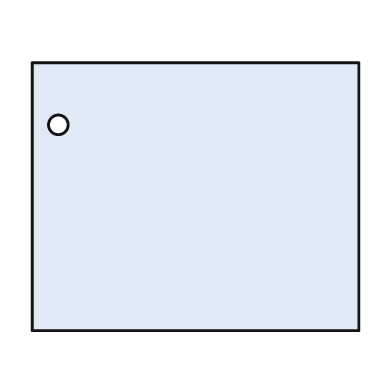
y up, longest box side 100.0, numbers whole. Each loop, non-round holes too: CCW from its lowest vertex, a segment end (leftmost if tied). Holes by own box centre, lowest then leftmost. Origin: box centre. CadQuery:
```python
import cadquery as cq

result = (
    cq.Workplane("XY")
    .moveTo(-50.0, -41.0)
    .lineTo(50.0, -41.0)
    .lineTo(50.0, 41.0)
    .lineTo(-50.0, 41.0)
    .close()
    .moveTo(-42.0, 22.0)
    .circle(3.0)
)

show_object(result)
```